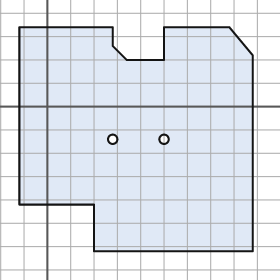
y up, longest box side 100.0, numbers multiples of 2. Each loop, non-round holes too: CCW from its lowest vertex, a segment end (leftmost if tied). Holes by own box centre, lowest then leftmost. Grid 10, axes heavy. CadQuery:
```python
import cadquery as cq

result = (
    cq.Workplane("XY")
    .moveTo(20.0, -62.0)
    .lineTo(88.0, -62.0)
    .lineTo(88.0, 22.0)
    .lineTo(78.0, 34.0)
    .lineTo(50.0, 34.0)
    .lineTo(50.0, 20.0)
    .lineTo(34.0, 20.0)
    .lineTo(28.0, 26.0)
    .lineTo(28.0, 34.0)
    .lineTo(-12.0, 34.0)
    .lineTo(-12.0, -42.0)
    .lineTo(20.0, -42.0)
    .close()
    .moveTo(28.0, -14.0)
    .circle(2.0)
    .moveTo(50.0, -14.0)
    .circle(2.0)
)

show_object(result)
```